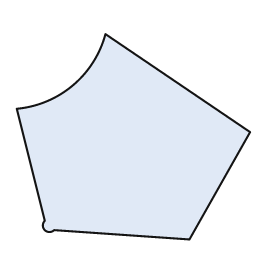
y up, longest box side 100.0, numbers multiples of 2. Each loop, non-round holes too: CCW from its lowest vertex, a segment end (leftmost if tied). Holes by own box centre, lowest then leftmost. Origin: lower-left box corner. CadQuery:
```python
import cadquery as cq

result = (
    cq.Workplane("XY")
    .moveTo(74.0, 0.0)
    .lineTo(100.0, 46.0)
    .lineTo(38.0, 88.0)
    .threePointArc((24.0, 66.0), (0.0, 56.0))
    .lineTo(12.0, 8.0)
    .threePointArc((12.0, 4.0), (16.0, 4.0))
    .close()
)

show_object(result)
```